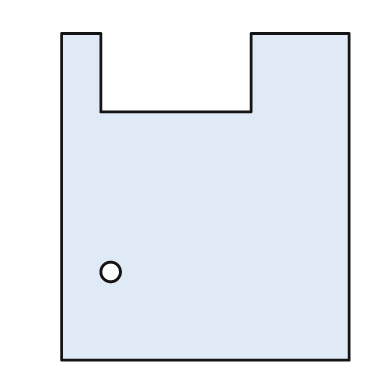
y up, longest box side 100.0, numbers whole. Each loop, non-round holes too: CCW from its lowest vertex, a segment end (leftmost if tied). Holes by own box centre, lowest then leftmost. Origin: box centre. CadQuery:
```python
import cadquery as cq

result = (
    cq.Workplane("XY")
    .moveTo(-44.0, -50.0)
    .lineTo(44.0, -50.0)
    .lineTo(44.0, 50.0)
    .lineTo(14.0, 50.0)
    .lineTo(14.0, 26.0)
    .lineTo(-32.0, 26.0)
    .lineTo(-32.0, 50.0)
    .lineTo(-44.0, 50.0)
    .close()
    .moveTo(-29.0, -23.0)
    .circle(3.0)
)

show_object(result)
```